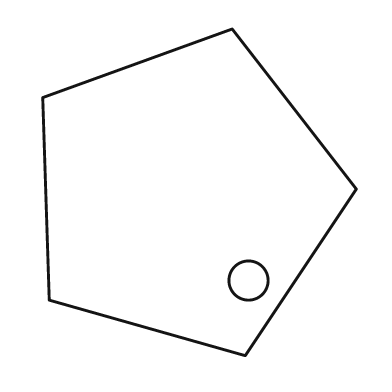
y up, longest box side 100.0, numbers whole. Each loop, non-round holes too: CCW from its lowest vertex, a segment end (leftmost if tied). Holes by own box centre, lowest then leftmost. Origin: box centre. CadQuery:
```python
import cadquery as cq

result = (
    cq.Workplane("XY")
    .moveTo(14.0, -50.0)
    .lineTo(48.0, 1.0)
    .lineTo(10.0, 50.0)
    .lineTo(-48.0, 29.0)
    .lineTo(-46.0, -33.0)
    .close()
    .moveTo(15.0, -27.0)
    .circle(6.0)
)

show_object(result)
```